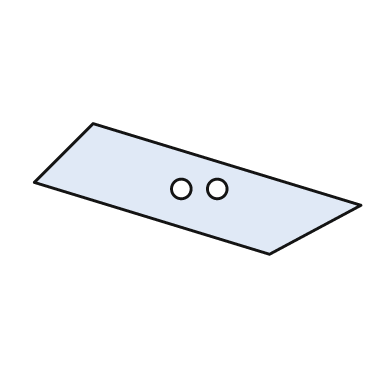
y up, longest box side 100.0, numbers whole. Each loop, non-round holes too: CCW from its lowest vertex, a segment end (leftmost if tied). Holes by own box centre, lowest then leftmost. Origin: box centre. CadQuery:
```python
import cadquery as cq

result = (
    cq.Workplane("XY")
    .moveTo(22.0, -20.0)
    .lineTo(50.0, -5.0)
    .lineTo(-32.0, 20.0)
    .lineTo(-50.0, 2.0)
    .close()
    .moveTo(-5.0, 0.0)
    .circle(3.0)
    .moveTo(6.0, 0.0)
    .circle(3.0)
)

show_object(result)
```